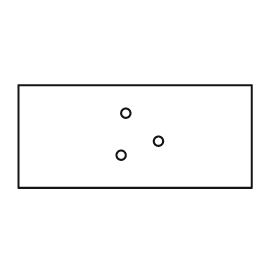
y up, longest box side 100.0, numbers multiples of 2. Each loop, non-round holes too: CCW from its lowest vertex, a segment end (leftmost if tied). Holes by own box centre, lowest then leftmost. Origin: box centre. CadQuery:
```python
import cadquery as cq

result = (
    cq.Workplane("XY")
    .moveTo(-50.0, -22.0)
    .lineTo(50.0, -22.0)
    .lineTo(50.0, 22.0)
    .lineTo(-50.0, 22.0)
    .close()
    .moveTo(-6.0, -8.0)
    .circle(2.0)
    .moveTo(10.0, -2.0)
    .circle(2.0)
    .moveTo(-4.0, 10.0)
    .circle(2.0)
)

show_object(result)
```